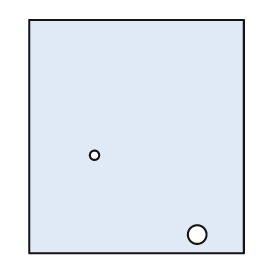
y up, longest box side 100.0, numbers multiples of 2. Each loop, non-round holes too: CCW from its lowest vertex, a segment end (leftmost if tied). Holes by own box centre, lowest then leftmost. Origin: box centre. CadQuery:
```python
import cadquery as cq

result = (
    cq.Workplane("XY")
    .moveTo(-46.0, -50.0)
    .lineTo(46.0, -50.0)
    .lineTo(46.0, 50.0)
    .lineTo(-46.0, 50.0)
    .close()
    .moveTo(26.0, -42.0)
    .circle(4.0)
    .moveTo(-18.0, -8.0)
    .circle(2.0)
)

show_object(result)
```